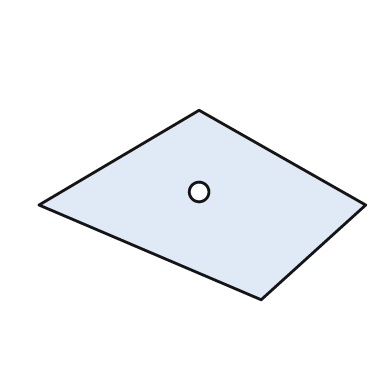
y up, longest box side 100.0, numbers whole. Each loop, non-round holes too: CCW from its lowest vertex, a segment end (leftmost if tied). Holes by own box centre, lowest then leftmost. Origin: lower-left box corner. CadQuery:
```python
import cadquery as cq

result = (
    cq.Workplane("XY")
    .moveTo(68.0, 0.0)
    .lineTo(100.0, 29.0)
    .lineTo(49.0, 58.0)
    .lineTo(0.0, 29.0)
    .close()
    .moveTo(49.0, 33.0)
    .circle(3.0)
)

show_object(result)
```